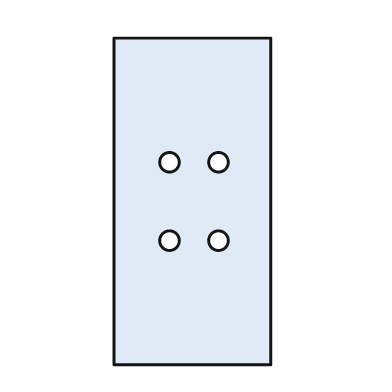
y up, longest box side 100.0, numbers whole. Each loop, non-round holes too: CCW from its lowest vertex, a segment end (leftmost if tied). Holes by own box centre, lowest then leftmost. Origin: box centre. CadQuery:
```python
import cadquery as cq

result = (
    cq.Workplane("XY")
    .moveTo(-24.0, -50.0)
    .lineTo(24.0, -50.0)
    .lineTo(24.0, 50.0)
    .lineTo(-24.0, 50.0)
    .close()
    .moveTo(-7.0, -12.0)
    .circle(3.0)
    .moveTo(8.0, -12.0)
    .circle(3.0)
    .moveTo(-7.0, 12.0)
    .circle(3.0)
    .moveTo(8.0, 12.0)
    .circle(3.0)
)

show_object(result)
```